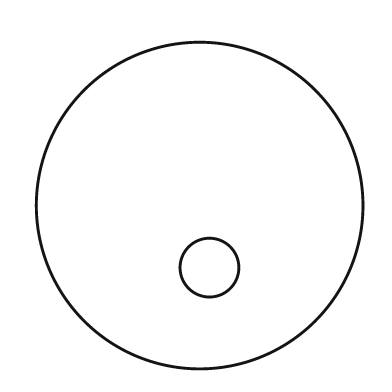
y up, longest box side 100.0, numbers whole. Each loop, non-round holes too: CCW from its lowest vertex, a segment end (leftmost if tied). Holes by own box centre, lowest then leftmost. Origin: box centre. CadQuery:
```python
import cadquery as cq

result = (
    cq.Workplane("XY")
    .moveTo(0.0, 0.0)
    .circle(50.0)
    .moveTo(3.0, -19.0)
    .circle(9.0)
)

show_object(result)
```